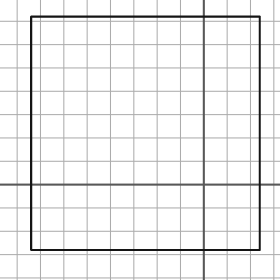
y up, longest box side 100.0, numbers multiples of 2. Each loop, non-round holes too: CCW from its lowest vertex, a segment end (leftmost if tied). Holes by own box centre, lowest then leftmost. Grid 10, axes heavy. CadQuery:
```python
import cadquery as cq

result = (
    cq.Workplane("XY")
    .moveTo(-74.0, -28.0)
    .lineTo(24.0, -28.0)
    .lineTo(24.0, 72.0)
    .lineTo(-74.0, 72.0)
    .close()
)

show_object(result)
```